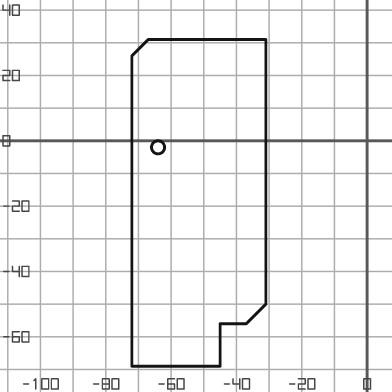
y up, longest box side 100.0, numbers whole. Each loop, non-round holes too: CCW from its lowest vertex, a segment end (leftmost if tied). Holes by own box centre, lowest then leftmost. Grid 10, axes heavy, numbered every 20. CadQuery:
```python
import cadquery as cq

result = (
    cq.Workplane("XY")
    .moveTo(-72.0, -69.0)
    .lineTo(-45.0, -69.0)
    .lineTo(-45.0, -56.0)
    .lineTo(-37.0, -56.0)
    .lineTo(-31.0, -50.0)
    .lineTo(-31.0, 31.0)
    .lineTo(-67.0, 31.0)
    .lineTo(-72.0, 26.0)
    .close()
    .moveTo(-64.0, -2.0)
    .circle(2.0)
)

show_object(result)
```